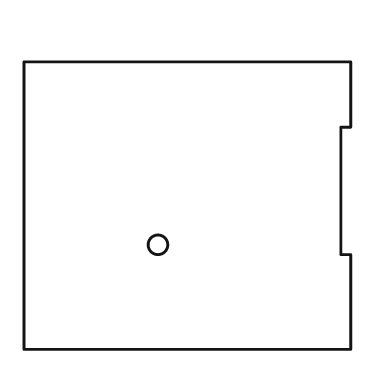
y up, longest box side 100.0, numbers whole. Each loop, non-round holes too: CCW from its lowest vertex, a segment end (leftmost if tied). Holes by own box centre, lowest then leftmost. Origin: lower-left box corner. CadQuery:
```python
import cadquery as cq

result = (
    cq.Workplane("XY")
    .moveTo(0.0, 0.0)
    .lineTo(100.0, 0.0)
    .lineTo(100.0, 29.0)
    .lineTo(97.0, 29.0)
    .lineTo(97.0, 68.0)
    .lineTo(100.0, 68.0)
    .lineTo(100.0, 88.0)
    .lineTo(0.0, 88.0)
    .close()
    .moveTo(41.0, 32.0)
    .circle(3.0)
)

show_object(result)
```